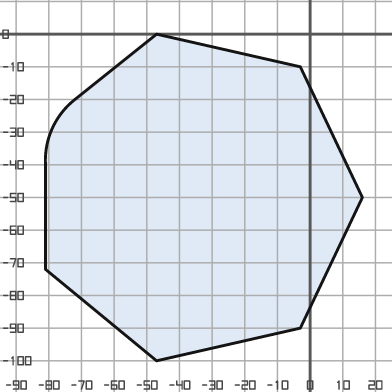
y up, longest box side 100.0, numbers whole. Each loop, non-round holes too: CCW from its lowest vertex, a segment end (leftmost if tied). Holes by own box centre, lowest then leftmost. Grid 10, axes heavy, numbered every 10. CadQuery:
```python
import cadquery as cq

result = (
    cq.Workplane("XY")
    .moveTo(-47.0, -100.0)
    .lineTo(-3.0, -90.0)
    .lineTo(16.0, -50.0)
    .lineTo(-3.0, -10.0)
    .lineTo(-47.0, 0.0)
    .lineTo(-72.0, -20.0)
    .threePointArc((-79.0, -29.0), (-81.0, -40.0))
    .lineTo(-81.0, -72.0)
    .close()
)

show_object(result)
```